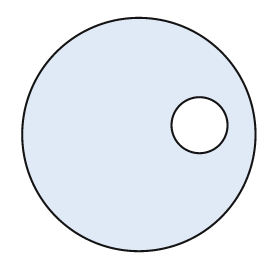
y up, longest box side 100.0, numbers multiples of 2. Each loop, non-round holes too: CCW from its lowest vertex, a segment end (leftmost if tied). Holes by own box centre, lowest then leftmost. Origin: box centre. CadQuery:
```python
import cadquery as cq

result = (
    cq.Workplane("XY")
    .moveTo(0.0, 0.0)
    .circle(50.0)
    .moveTo(26.0, 4.0)
    .circle(12.0)
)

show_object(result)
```